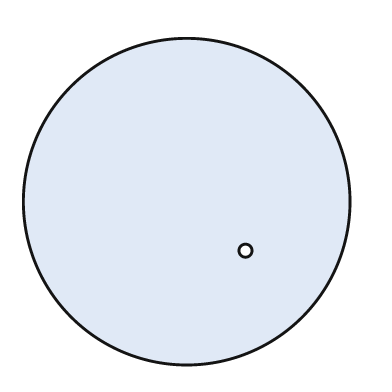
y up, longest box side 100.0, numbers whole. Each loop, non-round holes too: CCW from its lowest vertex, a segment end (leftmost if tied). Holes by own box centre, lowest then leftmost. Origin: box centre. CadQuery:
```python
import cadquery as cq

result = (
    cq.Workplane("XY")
    .moveTo(0.0, 0.0)
    .circle(50.0)
    .moveTo(18.0, -15.0)
    .circle(2.0)
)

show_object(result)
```